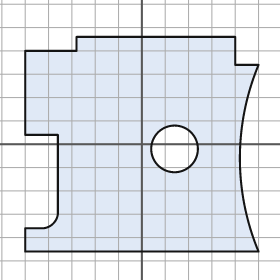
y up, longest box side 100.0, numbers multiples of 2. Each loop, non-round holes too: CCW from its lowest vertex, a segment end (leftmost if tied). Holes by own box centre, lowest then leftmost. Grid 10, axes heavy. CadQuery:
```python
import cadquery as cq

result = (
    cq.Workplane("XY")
    .moveTo(-50.0, -46.0)
    .lineTo(50.0, -46.0)
    .threePointArc((42.0, -6.0), (50.0, 34.0))
    .lineTo(40.0, 34.0)
    .lineTo(40.0, 46.0)
    .lineTo(-28.0, 46.0)
    .lineTo(-28.0, 40.0)
    .lineTo(-50.0, 40.0)
    .lineTo(-50.0, 4.0)
    .lineTo(-36.0, 4.0)
    .lineTo(-36.0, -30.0)
    .threePointArc((-38.0, -34.0), (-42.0, -36.0))
    .lineTo(-50.0, -36.0)
    .close()
    .moveTo(14.0, -2.0)
    .circle(10.0)
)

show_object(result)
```